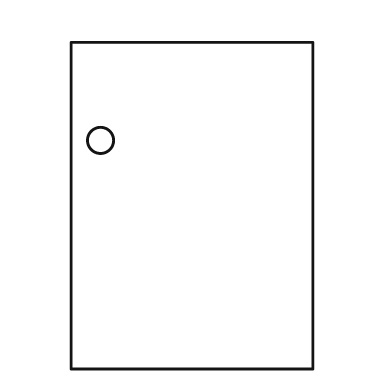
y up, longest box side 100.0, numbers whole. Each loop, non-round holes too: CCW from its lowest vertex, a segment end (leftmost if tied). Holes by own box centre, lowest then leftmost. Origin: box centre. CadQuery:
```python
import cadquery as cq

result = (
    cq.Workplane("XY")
    .moveTo(-37.0, -50.0)
    .lineTo(37.0, -50.0)
    .lineTo(37.0, 50.0)
    .lineTo(-37.0, 50.0)
    .close()
    .moveTo(-28.0, 20.0)
    .circle(4.0)
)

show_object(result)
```